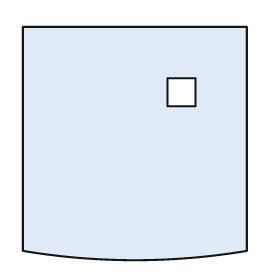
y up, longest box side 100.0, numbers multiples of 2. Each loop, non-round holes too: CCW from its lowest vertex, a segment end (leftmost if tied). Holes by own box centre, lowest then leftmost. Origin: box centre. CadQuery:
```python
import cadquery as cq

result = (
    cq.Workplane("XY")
    .moveTo(-48.0, -46.0)
    .threePointArc((0.0, -50.0), (48.0, -46.0))
    .lineTo(48.0, 50.0)
    .lineTo(-48.0, 50.0)
    .close()
    .moveTo(14.0, 16.0)
    .lineTo(26.0, 16.0)
    .lineTo(26.0, 28.0)
    .lineTo(14.0, 28.0)
    .close()
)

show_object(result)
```